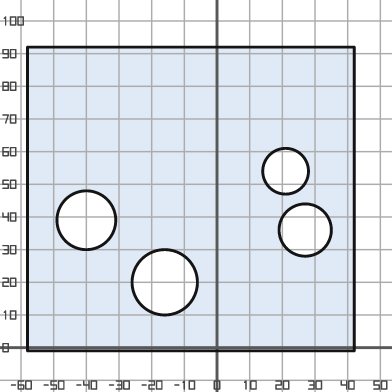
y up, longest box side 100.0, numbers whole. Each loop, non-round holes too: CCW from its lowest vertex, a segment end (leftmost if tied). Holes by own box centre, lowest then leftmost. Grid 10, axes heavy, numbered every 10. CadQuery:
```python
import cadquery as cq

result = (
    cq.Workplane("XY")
    .moveTo(-58.0, -1.0)
    .lineTo(42.0, -1.0)
    .lineTo(42.0, 92.0)
    .lineTo(-58.0, 92.0)
    .close()
    .moveTo(-16.0, 20.0)
    .circle(10.0)
    .moveTo(27.0, 36.0)
    .circle(8.0)
    .moveTo(-40.0, 39.0)
    .circle(9.0)
    .moveTo(21.0, 54.0)
    .circle(7.0)
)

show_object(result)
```